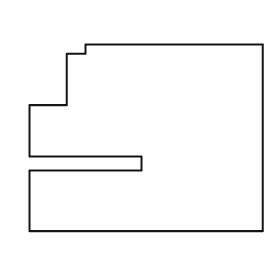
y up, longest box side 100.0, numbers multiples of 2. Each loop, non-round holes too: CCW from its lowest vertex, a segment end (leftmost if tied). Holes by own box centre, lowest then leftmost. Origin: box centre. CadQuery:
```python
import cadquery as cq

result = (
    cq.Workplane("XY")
    .moveTo(-50.0, -40.0)
    .lineTo(50.0, -40.0)
    .lineTo(50.0, 40.0)
    .lineTo(-26.0, 40.0)
    .lineTo(-26.0, 36.0)
    .lineTo(-34.0, 36.0)
    .lineTo(-34.0, 14.0)
    .lineTo(-50.0, 14.0)
    .lineTo(-50.0, -8.0)
    .lineTo(-2.0, -8.0)
    .lineTo(-2.0, -14.0)
    .lineTo(-50.0, -14.0)
    .close()
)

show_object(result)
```